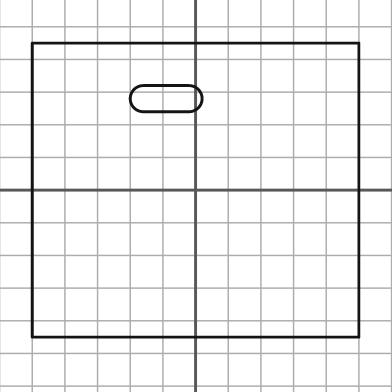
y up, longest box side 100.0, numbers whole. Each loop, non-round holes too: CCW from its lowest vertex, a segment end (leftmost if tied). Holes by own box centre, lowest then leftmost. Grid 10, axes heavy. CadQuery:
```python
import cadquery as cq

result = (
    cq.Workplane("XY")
    .moveTo(-50.0, -45.0)
    .lineTo(50.0, -45.0)
    .lineTo(50.0, 45.0)
    .lineTo(-50.0, 45.0)
    .close()
    .moveTo(-16.0, 24.0)
    .lineTo(-2.0, 24.0)
    .threePointArc((2.0, 28.0), (-2.0, 32.0))
    .lineTo(-16.0, 32.0)
    .threePointArc((-20.0, 28.0), (-16.0, 24.0))
    .close()
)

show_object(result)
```